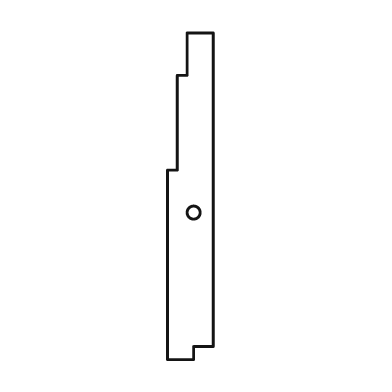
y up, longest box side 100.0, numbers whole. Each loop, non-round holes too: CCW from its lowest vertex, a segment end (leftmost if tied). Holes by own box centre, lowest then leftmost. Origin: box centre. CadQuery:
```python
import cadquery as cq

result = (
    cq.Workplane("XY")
    .moveTo(-7.0, -50.0)
    .lineTo(1.0, -50.0)
    .lineTo(1.0, -46.0)
    .lineTo(7.0, -46.0)
    .lineTo(7.0, 50.0)
    .lineTo(-1.0, 50.0)
    .lineTo(-1.0, 37.0)
    .lineTo(-4.0, 37.0)
    .lineTo(-4.0, 8.0)
    .lineTo(-7.0, 8.0)
    .close()
    .moveTo(1.0, -5.0)
    .circle(2.0)
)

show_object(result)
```